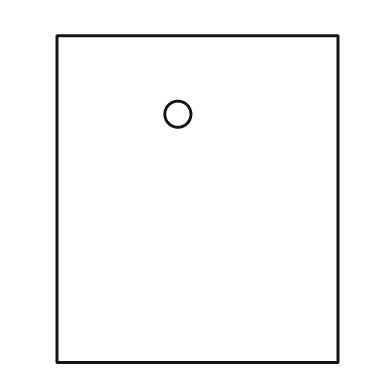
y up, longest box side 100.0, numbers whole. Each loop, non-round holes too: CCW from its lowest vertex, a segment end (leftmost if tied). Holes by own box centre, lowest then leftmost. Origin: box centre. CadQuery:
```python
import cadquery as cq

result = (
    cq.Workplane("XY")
    .moveTo(-43.0, -50.0)
    .lineTo(43.0, -50.0)
    .lineTo(43.0, 50.0)
    .lineTo(-43.0, 50.0)
    .close()
    .moveTo(-6.0, 26.0)
    .circle(4.0)
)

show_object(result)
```